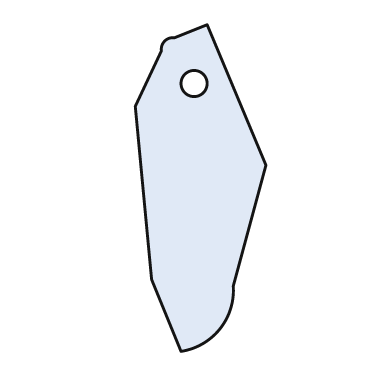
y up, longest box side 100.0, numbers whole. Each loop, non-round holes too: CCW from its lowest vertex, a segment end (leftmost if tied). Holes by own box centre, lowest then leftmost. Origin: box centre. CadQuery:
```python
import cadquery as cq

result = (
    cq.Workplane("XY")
    .moveTo(-6.0, -50.0)
    .threePointArc((6.0, -43.0), (10.0, -30.0))
    .lineTo(20.0, 7.0)
    .lineTo(2.0, 50.0)
    .lineTo(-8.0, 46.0)
    .threePointArc((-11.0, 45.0), (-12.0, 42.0))
    .lineTo(-20.0, 25.0)
    .lineTo(-15.0, -28.0)
    .close()
    .moveTo(-2.0, 32.0)
    .circle(4.0)
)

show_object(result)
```